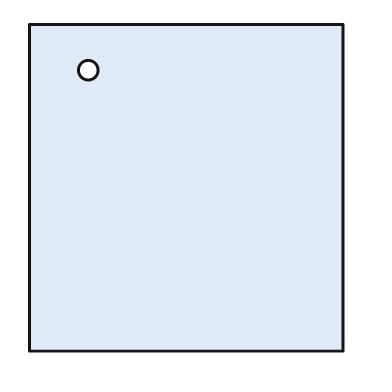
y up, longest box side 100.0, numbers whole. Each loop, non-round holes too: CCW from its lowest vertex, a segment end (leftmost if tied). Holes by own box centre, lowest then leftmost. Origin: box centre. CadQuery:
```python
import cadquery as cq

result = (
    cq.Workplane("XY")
    .moveTo(-48.0, -50.0)
    .lineTo(48.0, -50.0)
    .lineTo(48.0, 50.0)
    .lineTo(-48.0, 50.0)
    .close()
    .moveTo(-30.0, 36.0)
    .circle(3.0)
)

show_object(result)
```